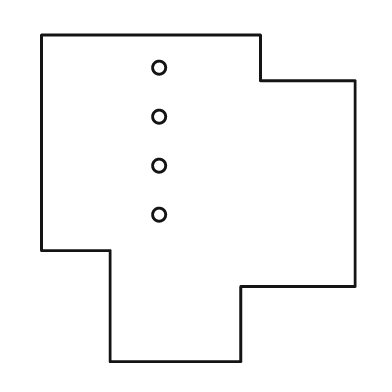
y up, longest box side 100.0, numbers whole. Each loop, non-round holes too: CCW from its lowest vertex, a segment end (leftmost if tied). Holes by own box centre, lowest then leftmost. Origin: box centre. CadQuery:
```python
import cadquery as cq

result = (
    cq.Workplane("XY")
    .moveTo(-27.0, -50.0)
    .lineTo(13.0, -50.0)
    .lineTo(13.0, -27.0)
    .lineTo(48.0, -27.0)
    .lineTo(48.0, 36.0)
    .lineTo(19.0, 36.0)
    .lineTo(19.0, 50.0)
    .lineTo(-48.0, 50.0)
    .lineTo(-48.0, -16.0)
    .lineTo(-27.0, -16.0)
    .close()
    .moveTo(-12.0, -5.0)
    .circle(2.0)
    .moveTo(-12.0, 10.0)
    .circle(2.0)
    .moveTo(-12.0, 25.0)
    .circle(2.0)
    .moveTo(-12.0, 40.0)
    .circle(2.0)
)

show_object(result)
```